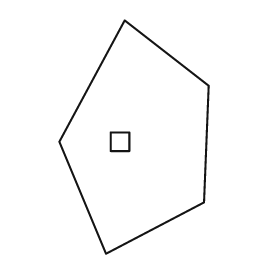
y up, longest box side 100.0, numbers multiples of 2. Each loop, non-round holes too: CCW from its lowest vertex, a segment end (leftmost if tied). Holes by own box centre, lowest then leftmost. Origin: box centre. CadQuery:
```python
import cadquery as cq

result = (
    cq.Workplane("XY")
    .moveTo(-12.0, -50.0)
    .lineTo(30.0, -28.0)
    .lineTo(32.0, 22.0)
    .lineTo(-4.0, 50.0)
    .lineTo(-32.0, -2.0)
    .close()
    .moveTo(-10.0, -6.0)
    .lineTo(-2.0, -6.0)
    .lineTo(-2.0, 2.0)
    .lineTo(-10.0, 2.0)
    .close()
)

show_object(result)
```